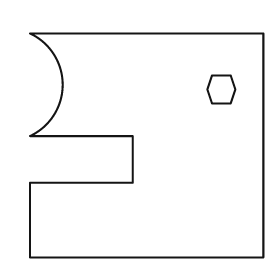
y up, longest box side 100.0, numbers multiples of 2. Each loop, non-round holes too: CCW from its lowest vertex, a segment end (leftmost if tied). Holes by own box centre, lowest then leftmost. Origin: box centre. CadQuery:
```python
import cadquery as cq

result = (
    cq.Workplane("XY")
    .moveTo(-50.0, -48.0)
    .lineTo(50.0, -48.0)
    .lineTo(50.0, 48.0)
    .lineTo(-50.0, 48.0)
    .threePointArc((-36.0, 26.0), (-50.0, 4.0))
    .lineTo(-6.0, 4.0)
    .lineTo(-6.0, -16.0)
    .lineTo(-50.0, -16.0)
    .close()
    .moveTo(28.0, 18.0)
    .lineTo(36.0, 18.0)
    .lineTo(38.0, 24.0)
    .lineTo(36.0, 30.0)
    .lineTo(28.0, 30.0)
    .lineTo(26.0, 24.0)
    .close()
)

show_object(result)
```